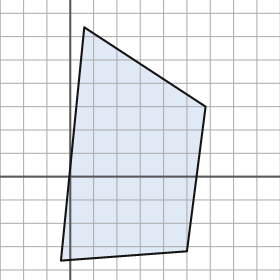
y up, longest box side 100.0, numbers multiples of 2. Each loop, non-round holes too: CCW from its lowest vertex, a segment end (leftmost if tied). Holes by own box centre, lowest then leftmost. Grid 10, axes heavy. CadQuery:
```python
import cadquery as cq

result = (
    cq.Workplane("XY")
    .moveTo(-4.0, -36.0)
    .lineTo(50.0, -32.0)
    .lineTo(58.0, 30.0)
    .lineTo(6.0, 64.0)
    .close()
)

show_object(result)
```